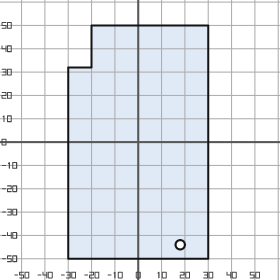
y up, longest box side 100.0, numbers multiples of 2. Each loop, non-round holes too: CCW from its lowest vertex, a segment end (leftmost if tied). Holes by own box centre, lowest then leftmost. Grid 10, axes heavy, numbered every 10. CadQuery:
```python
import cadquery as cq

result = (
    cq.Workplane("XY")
    .moveTo(-30.0, -50.0)
    .lineTo(30.0, -50.0)
    .lineTo(30.0, 50.0)
    .lineTo(-20.0, 50.0)
    .lineTo(-20.0, 32.0)
    .lineTo(-30.0, 32.0)
    .close()
    .moveTo(18.0, -44.0)
    .circle(2.0)
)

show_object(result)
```